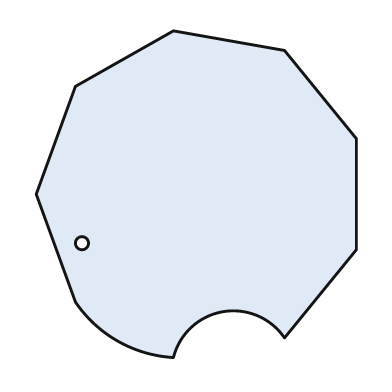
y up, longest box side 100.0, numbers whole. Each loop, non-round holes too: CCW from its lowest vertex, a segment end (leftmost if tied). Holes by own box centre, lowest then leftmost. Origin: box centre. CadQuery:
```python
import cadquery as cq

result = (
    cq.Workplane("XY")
    .moveTo(-7.0, -50.0)
    .threePointArc((8.0, -36.0), (27.0, -44.0))
    .lineTo(49.0, -17.0)
    .lineTo(49.0, 17.0)
    .lineTo(27.0, 44.0)
    .lineTo(-7.0, 50.0)
    .lineTo(-37.0, 33.0)
    .lineTo(-49.0, 0.0)
    .lineTo(-37.0, -33.0)
    .threePointArc((-24.0, -45.0), (-7.0, -50.0))
    .close()
    .moveTo(-35.0, -15.0)
    .circle(2.0)
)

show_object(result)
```